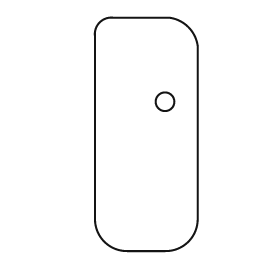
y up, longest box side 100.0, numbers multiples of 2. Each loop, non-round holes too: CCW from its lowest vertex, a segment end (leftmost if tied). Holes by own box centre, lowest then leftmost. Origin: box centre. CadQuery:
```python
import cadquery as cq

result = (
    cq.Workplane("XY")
    .moveTo(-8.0, -50.0)
    .lineTo(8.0, -50.0)
    .threePointArc((18.0, -46.0), (22.0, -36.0))
    .lineTo(22.0, 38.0)
    .threePointArc((18.0, 46.0), (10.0, 50.0))
    .lineTo(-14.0, 50.0)
    .threePointArc((-20.0, 48.0), (-22.0, 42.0))
    .lineTo(-22.0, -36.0)
    .threePointArc((-18.0, -46.0), (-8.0, -50.0))
    .close()
    .moveTo(8.0, 14.0)
    .circle(4.0)
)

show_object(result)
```